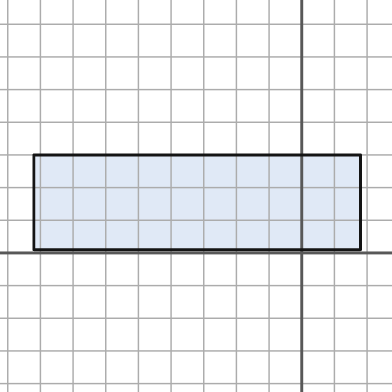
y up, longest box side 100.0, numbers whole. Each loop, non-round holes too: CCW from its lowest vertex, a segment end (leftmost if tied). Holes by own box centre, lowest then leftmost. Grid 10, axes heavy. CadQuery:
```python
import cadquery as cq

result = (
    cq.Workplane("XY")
    .moveTo(-82.0, 1.0)
    .lineTo(18.0, 1.0)
    .lineTo(18.0, 30.0)
    .lineTo(-82.0, 30.0)
    .close()
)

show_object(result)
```